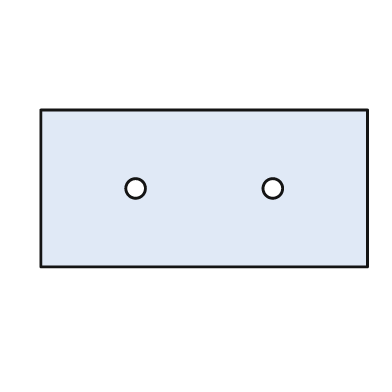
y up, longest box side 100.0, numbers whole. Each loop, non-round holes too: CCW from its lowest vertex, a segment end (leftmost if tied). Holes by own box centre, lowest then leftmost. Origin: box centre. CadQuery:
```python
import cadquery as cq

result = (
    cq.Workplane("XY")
    .moveTo(-50.0, -24.0)
    .lineTo(50.0, -24.0)
    .lineTo(50.0, 24.0)
    .lineTo(-50.0, 24.0)
    .close()
    .moveTo(-21.0, 0.0)
    .circle(3.0)
    .moveTo(21.0, 0.0)
    .circle(3.0)
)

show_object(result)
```